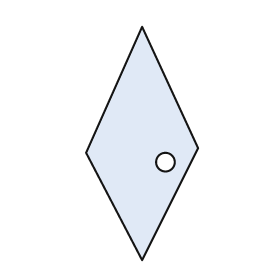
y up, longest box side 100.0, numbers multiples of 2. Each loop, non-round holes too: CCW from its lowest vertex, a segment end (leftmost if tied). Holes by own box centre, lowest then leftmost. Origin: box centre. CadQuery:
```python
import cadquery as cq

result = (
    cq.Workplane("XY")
    .moveTo(0.0, -50.0)
    .lineTo(24.0, -2.0)
    .lineTo(0.0, 50.0)
    .lineTo(-24.0, -4.0)
    .close()
    .moveTo(10.0, -8.0)
    .circle(4.0)
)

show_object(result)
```